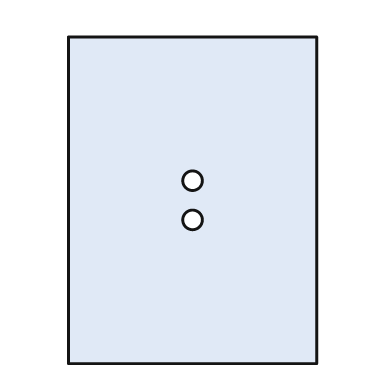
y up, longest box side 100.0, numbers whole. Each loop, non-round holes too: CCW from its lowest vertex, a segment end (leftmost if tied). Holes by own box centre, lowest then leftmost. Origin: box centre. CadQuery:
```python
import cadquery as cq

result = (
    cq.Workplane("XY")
    .moveTo(-38.0, -50.0)
    .lineTo(38.0, -50.0)
    .lineTo(38.0, 50.0)
    .lineTo(-38.0, 50.0)
    .close()
    .moveTo(0.0, -6.0)
    .circle(3.0)
    .moveTo(0.0, 6.0)
    .circle(3.0)
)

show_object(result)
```